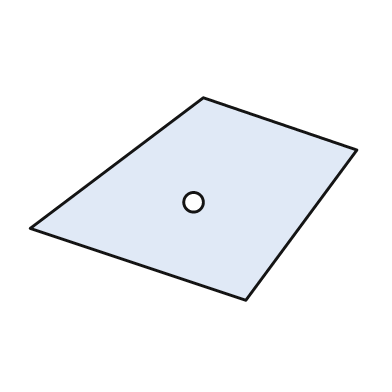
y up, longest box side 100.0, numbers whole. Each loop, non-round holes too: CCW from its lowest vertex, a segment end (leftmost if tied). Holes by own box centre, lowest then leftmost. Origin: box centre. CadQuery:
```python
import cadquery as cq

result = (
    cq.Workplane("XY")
    .moveTo(16.0, -31.0)
    .lineTo(50.0, 15.0)
    .lineTo(3.0, 31.0)
    .lineTo(-50.0, -9.0)
    .close()
    .moveTo(0.0, -1.0)
    .circle(3.0)
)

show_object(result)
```